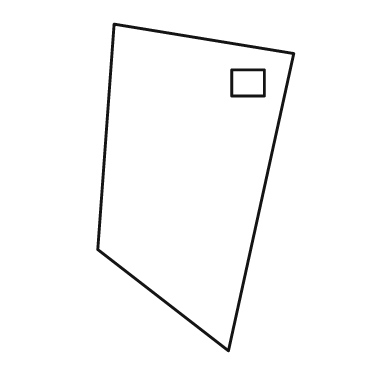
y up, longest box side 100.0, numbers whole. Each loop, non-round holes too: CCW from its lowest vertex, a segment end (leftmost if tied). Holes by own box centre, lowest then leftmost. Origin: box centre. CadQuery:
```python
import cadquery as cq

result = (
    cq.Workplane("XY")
    .moveTo(10.0, -50.0)
    .lineTo(30.0, 41.0)
    .lineTo(-25.0, 50.0)
    .lineTo(-30.0, -19.0)
    .close()
    .moveTo(11.0, 28.0)
    .lineTo(21.0, 28.0)
    .lineTo(21.0, 36.0)
    .lineTo(11.0, 36.0)
    .close()
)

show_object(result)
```